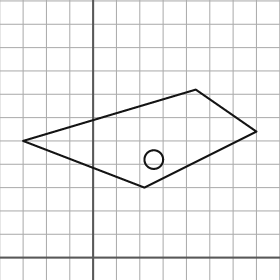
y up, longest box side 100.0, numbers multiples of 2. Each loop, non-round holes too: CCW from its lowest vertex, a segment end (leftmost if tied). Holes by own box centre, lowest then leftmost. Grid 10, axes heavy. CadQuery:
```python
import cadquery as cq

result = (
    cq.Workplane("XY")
    .moveTo(22.0, 30.0)
    .lineTo(70.0, 54.0)
    .lineTo(44.0, 72.0)
    .lineTo(-30.0, 50.0)
    .close()
    .moveTo(26.0, 42.0)
    .circle(4.0)
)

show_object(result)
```